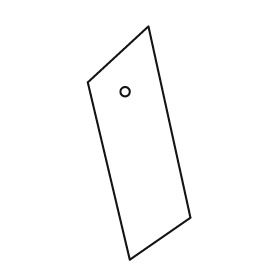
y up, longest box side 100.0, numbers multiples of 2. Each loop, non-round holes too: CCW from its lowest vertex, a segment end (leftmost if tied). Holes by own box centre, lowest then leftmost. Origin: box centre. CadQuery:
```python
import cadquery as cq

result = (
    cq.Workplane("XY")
    .moveTo(-4.0, -50.0)
    .lineTo(22.0, -32.0)
    .lineTo(4.0, 50.0)
    .lineTo(-22.0, 26.0)
    .close()
    .moveTo(-6.0, 22.0)
    .circle(2.0)
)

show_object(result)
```